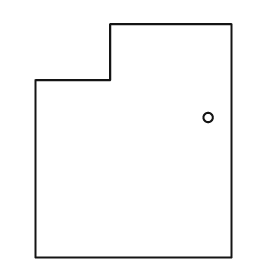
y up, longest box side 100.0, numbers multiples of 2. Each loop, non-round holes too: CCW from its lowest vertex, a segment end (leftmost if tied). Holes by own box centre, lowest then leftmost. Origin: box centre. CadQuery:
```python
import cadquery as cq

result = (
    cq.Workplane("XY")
    .moveTo(-42.0, -50.0)
    .lineTo(42.0, -50.0)
    .lineTo(42.0, 50.0)
    .lineTo(-10.0, 50.0)
    .lineTo(-10.0, 26.0)
    .lineTo(-42.0, 26.0)
    .close()
    .moveTo(32.0, 10.0)
    .circle(2.0)
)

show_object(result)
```